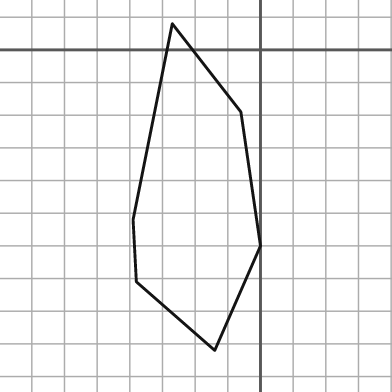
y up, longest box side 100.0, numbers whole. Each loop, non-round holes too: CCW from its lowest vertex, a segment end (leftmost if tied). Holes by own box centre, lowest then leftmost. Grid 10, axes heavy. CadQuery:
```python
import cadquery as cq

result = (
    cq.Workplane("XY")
    .moveTo(-14.0, -92.0)
    .lineTo(0.0, -60.0)
    .lineTo(-6.0, -19.0)
    .lineTo(-27.0, 8.0)
    .lineTo(-39.0, -52.0)
    .lineTo(-38.0, -71.0)
    .close()
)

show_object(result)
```